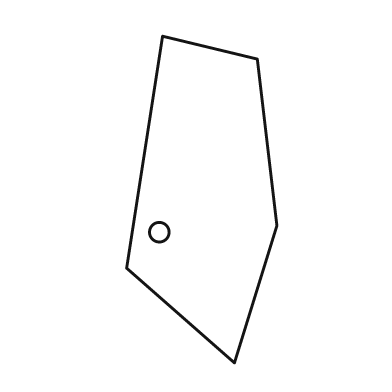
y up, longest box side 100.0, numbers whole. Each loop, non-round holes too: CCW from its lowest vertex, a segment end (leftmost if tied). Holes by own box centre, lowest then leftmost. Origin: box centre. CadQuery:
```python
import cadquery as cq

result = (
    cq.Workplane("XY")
    .moveTo(10.0, -50.0)
    .lineTo(23.0, -8.0)
    .lineTo(17.0, 43.0)
    .lineTo(-12.0, 50.0)
    .lineTo(-23.0, -21.0)
    .close()
    .moveTo(-13.0, -10.0)
    .circle(3.0)
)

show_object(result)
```